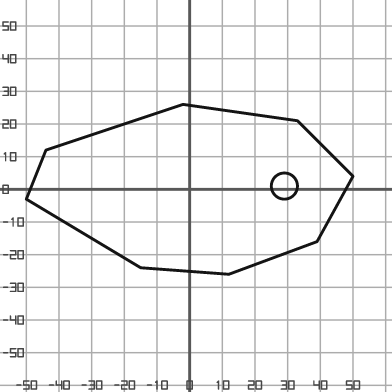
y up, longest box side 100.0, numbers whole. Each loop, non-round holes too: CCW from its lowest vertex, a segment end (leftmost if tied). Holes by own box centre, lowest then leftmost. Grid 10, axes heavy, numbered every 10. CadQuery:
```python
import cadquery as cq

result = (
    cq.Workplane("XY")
    .moveTo(12.0, -26.0)
    .lineTo(39.0, -16.0)
    .lineTo(50.0, 4.0)
    .lineTo(33.0, 21.0)
    .lineTo(-2.0, 26.0)
    .lineTo(-44.0, 12.0)
    .lineTo(-50.0, -3.0)
    .lineTo(-15.0, -24.0)
    .close()
    .moveTo(29.0, 1.0)
    .circle(4.0)
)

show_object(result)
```